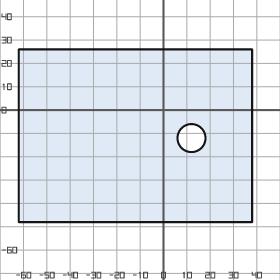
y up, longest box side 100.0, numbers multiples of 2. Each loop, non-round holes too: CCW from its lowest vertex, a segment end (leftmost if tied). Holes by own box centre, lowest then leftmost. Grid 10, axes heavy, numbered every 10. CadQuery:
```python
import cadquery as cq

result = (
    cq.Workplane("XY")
    .moveTo(-62.0, -48.0)
    .lineTo(38.0, -48.0)
    .lineTo(38.0, 26.0)
    .lineTo(-62.0, 26.0)
    .close()
    .moveTo(12.0, -12.0)
    .circle(6.0)
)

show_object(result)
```